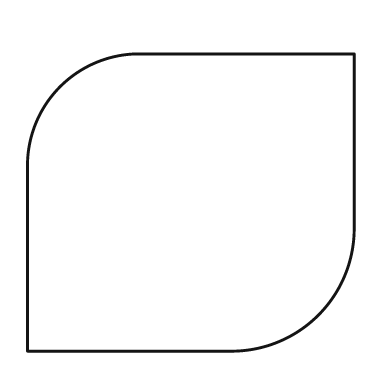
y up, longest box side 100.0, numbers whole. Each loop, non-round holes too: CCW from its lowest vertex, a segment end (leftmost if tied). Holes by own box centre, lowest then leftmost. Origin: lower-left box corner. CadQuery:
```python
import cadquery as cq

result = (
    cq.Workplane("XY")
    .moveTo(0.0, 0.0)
    .lineTo(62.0, 0.0)
    .threePointArc((89.0, 11.0), (100.0, 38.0))
    .lineTo(100.0, 91.0)
    .lineTo(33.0, 91.0)
    .threePointArc((10.0, 81.0), (0.0, 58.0))
    .close()
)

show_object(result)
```